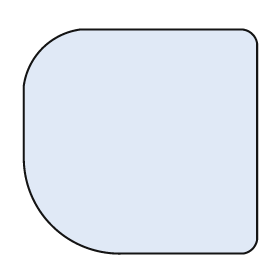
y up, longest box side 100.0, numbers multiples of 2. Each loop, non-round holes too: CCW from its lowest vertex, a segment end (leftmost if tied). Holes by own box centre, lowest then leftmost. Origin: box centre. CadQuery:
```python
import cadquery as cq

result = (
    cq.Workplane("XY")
    .moveTo(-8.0, -48.0)
    .lineTo(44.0, -48.0)
    .threePointArc((48.0, -46.0), (50.0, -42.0))
    .lineTo(50.0, 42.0)
    .threePointArc((48.0, 46.0), (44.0, 48.0))
    .lineTo(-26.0, 48.0)
    .threePointArc((-42.0, 40.0), (-50.0, 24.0))
    .lineTo(-50.0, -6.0)
    .threePointArc((-38.0, -36.0), (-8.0, -48.0))
    .close()
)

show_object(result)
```